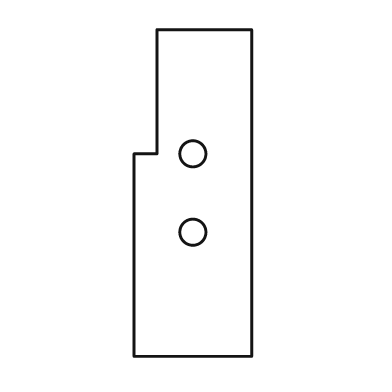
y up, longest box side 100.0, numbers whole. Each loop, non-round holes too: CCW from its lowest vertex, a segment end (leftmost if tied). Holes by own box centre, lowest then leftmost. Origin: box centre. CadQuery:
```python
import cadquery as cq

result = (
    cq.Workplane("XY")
    .moveTo(-18.0, -50.0)
    .lineTo(18.0, -50.0)
    .lineTo(18.0, 50.0)
    .lineTo(-11.0, 50.0)
    .lineTo(-11.0, 12.0)
    .lineTo(-18.0, 12.0)
    .close()
    .moveTo(0.0, -12.0)
    .circle(4.0)
    .moveTo(0.0, 12.0)
    .circle(4.0)
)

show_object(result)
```